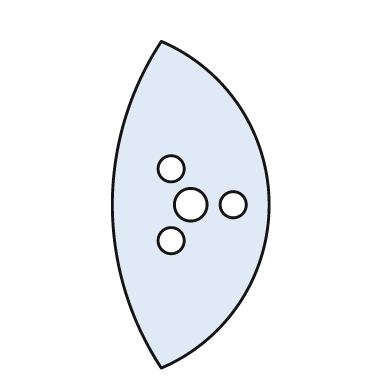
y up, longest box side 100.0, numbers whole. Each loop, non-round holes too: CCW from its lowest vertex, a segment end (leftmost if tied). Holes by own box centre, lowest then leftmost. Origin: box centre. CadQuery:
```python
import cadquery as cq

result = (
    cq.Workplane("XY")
    .moveTo(-9.0, -50.0)
    .threePointArc((24.0, 0.0), (-9.0, 50.0))
    .threePointArc((-24.0, 0.0), (-9.0, -50.0))
    .close()
    .moveTo(-6.0, -11.0)
    .circle(4.0)
    .moveTo(0.0, 0.0)
    .circle(5.0)
    .moveTo(13.0, 0.0)
    .circle(4.0)
    .moveTo(-6.0, 11.0)
    .circle(4.0)
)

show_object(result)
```